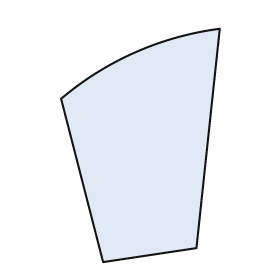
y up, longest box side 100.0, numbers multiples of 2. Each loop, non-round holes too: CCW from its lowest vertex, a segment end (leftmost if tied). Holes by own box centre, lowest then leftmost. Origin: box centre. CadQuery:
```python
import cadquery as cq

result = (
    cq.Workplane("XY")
    .moveTo(-16.0, -50.0)
    .lineTo(24.0, -44.0)
    .lineTo(34.0, 50.0)
    .threePointArc((-2.0, 40.0), (-34.0, 20.0))
    .close()
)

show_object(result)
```